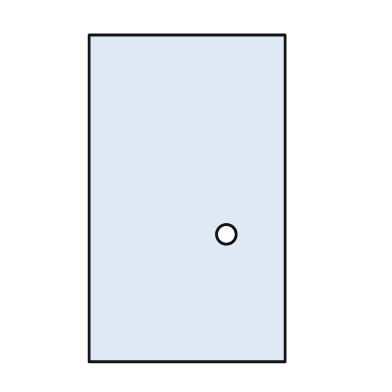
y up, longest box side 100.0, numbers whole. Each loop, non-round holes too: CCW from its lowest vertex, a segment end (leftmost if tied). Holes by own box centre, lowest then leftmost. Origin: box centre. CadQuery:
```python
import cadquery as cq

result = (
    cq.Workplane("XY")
    .moveTo(-30.0, -50.0)
    .lineTo(30.0, -50.0)
    .lineTo(30.0, 50.0)
    .lineTo(-30.0, 50.0)
    .close()
    .moveTo(12.0, -11.0)
    .circle(3.0)
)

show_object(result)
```